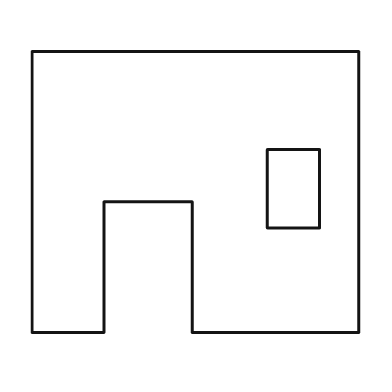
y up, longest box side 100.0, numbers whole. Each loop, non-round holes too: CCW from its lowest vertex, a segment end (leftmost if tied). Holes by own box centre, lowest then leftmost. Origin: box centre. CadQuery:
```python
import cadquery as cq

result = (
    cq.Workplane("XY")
    .moveTo(-50.0, -43.0)
    .lineTo(-28.0, -43.0)
    .lineTo(-28.0, -3.0)
    .lineTo(-1.0, -3.0)
    .lineTo(-1.0, -43.0)
    .lineTo(50.0, -43.0)
    .lineTo(50.0, 43.0)
    .lineTo(-50.0, 43.0)
    .close()
    .moveTo(22.0, -11.0)
    .lineTo(38.0, -11.0)
    .lineTo(38.0, 13.0)
    .lineTo(22.0, 13.0)
    .close()
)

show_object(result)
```